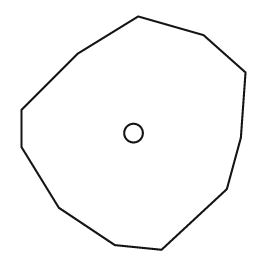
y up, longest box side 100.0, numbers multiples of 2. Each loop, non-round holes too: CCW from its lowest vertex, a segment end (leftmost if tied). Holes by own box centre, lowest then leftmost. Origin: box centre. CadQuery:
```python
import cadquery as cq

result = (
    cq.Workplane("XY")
    .moveTo(12.0, -50.0)
    .lineTo(40.0, -24.0)
    .lineTo(46.0, -2.0)
    .lineTo(48.0, 26.0)
    .lineTo(30.0, 42.0)
    .lineTo(2.0, 50.0)
    .lineTo(-24.0, 34.0)
    .lineTo(-48.0, 10.0)
    .lineTo(-48.0, -6.0)
    .lineTo(-32.0, -32.0)
    .lineTo(-8.0, -48.0)
    .close()
    .moveTo(0.0, 0.0)
    .circle(4.0)
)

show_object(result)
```